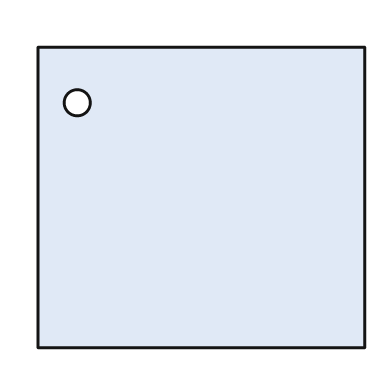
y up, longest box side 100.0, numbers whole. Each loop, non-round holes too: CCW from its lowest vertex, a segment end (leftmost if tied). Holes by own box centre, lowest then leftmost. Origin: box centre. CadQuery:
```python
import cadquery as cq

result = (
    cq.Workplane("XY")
    .moveTo(-50.0, -46.0)
    .lineTo(50.0, -46.0)
    .lineTo(50.0, 46.0)
    .lineTo(-50.0, 46.0)
    .close()
    .moveTo(-38.0, 29.0)
    .circle(4.0)
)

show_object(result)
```